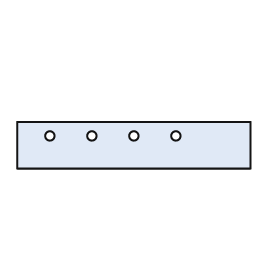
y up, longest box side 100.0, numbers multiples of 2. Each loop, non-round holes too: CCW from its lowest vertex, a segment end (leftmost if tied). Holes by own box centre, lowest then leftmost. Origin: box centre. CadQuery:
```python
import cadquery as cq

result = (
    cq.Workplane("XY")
    .moveTo(-50.0, -10.0)
    .lineTo(50.0, -10.0)
    .lineTo(50.0, 10.0)
    .lineTo(-50.0, 10.0)
    .close()
    .moveTo(-36.0, 4.0)
    .circle(2.0)
    .moveTo(-18.0, 4.0)
    .circle(2.0)
    .moveTo(0.0, 4.0)
    .circle(2.0)
    .moveTo(18.0, 4.0)
    .circle(2.0)
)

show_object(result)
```